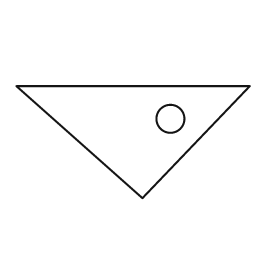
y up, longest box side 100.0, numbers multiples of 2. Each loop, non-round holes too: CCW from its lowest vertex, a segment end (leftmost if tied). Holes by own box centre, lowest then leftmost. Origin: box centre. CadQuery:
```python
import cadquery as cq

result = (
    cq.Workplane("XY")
    .moveTo(4.0, -24.0)
    .lineTo(50.0, 24.0)
    .lineTo(-50.0, 24.0)
    .close()
    .moveTo(16.0, 10.0)
    .circle(6.0)
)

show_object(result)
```